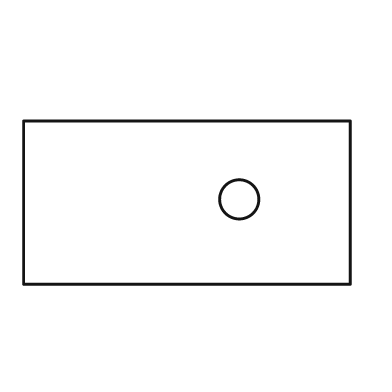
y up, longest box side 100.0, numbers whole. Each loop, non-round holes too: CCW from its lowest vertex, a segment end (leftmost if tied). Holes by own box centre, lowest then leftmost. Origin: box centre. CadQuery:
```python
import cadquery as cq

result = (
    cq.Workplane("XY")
    .moveTo(-50.0, -25.0)
    .lineTo(50.0, -25.0)
    .lineTo(50.0, 25.0)
    .lineTo(-50.0, 25.0)
    .close()
    .moveTo(16.0, 1.0)
    .circle(6.0)
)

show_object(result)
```